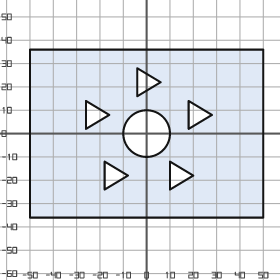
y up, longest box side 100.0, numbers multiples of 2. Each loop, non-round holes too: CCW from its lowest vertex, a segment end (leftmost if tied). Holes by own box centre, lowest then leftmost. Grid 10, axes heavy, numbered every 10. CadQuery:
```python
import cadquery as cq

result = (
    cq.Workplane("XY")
    .moveTo(-50.0, -36.0)
    .lineTo(50.0, -36.0)
    .lineTo(50.0, 36.0)
    .lineTo(-50.0, 36.0)
    .close()
    .moveTo(-18.0, -24.0)
    .lineTo(-8.0, -18.0)
    .lineTo(-18.0, -12.0)
    .close()
    .moveTo(10.0, -24.0)
    .lineTo(20.0, -18.0)
    .lineTo(10.0, -12.0)
    .close()
    .moveTo(0.0, 0.0)
    .circle(10.0)
    .moveTo(-26.0, 2.0)
    .lineTo(-16.0, 8.0)
    .lineTo(-26.0, 14.0)
    .close()
    .moveTo(18.0, 2.0)
    .lineTo(28.0, 8.0)
    .lineTo(18.0, 14.0)
    .close()
    .moveTo(-4.0, 16.0)
    .lineTo(6.0, 22.0)
    .lineTo(-4.0, 28.0)
    .close()
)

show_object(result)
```